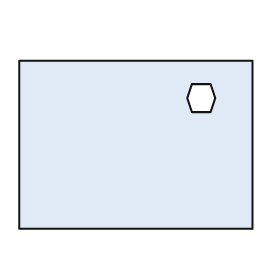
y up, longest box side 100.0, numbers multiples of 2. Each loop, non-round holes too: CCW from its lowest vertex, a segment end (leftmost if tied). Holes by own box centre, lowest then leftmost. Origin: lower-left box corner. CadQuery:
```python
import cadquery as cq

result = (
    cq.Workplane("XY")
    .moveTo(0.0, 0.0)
    .lineTo(100.0, 0.0)
    .lineTo(100.0, 72.0)
    .lineTo(0.0, 72.0)
    .close()
    .moveTo(74.0, 50.0)
    .lineTo(82.0, 50.0)
    .lineTo(84.0, 56.0)
    .lineTo(82.0, 62.0)
    .lineTo(74.0, 62.0)
    .lineTo(72.0, 56.0)
    .close()
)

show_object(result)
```